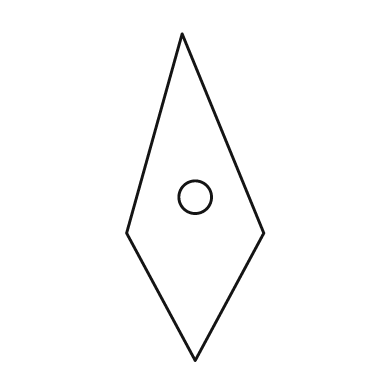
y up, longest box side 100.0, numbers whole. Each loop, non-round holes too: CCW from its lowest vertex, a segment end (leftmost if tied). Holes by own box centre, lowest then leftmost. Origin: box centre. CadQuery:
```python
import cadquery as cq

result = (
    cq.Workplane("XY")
    .moveTo(0.0, -50.0)
    .lineTo(21.0, -11.0)
    .lineTo(-4.0, 50.0)
    .lineTo(-21.0, -11.0)
    .close()
    .moveTo(0.0, 0.0)
    .circle(5.0)
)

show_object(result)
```